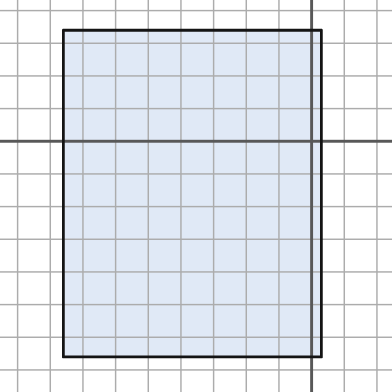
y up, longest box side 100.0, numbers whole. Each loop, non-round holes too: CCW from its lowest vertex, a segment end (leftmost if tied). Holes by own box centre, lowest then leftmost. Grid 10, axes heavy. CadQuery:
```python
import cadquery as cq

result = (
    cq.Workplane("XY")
    .moveTo(-76.0, -66.0)
    .lineTo(3.0, -66.0)
    .lineTo(3.0, 34.0)
    .lineTo(-76.0, 34.0)
    .close()
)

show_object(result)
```